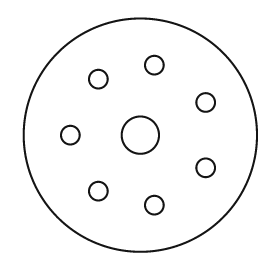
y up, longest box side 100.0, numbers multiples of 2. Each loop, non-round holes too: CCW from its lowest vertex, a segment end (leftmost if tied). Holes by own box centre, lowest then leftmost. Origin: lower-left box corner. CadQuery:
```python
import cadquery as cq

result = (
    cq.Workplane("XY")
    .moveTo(50.0, 50.0)
    .circle(50.0)
    .moveTo(56.0, 20.0)
    .circle(4.0)
    .moveTo(32.0, 26.0)
    .circle(4.0)
    .moveTo(78.0, 36.0)
    .circle(4.0)
    .moveTo(20.0, 50.0)
    .circle(4.0)
    .moveTo(50.0, 50.0)
    .circle(8.0)
    .moveTo(78.0, 64.0)
    .circle(4.0)
    .moveTo(32.0, 74.0)
    .circle(4.0)
    .moveTo(56.0, 80.0)
    .circle(4.0)
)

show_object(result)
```